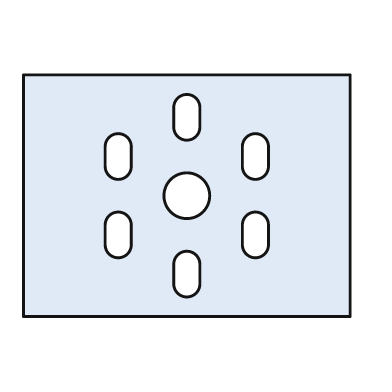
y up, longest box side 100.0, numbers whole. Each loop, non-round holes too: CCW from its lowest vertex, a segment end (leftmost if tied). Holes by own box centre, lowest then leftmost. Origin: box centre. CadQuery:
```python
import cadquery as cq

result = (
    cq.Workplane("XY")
    .moveTo(-50.0, -37.0)
    .lineTo(50.0, -37.0)
    .lineTo(50.0, 37.0)
    .lineTo(-50.0, 37.0)
    .close()
    .moveTo(-4.0, -27.0)
    .threePointArc((0.0, -31.0), (4.0, -27.0))
    .lineTo(4.0, -21.0)
    .threePointArc((0.0, -17.0), (-4.0, -21.0))
    .close()
    .moveTo(-25.0, -15.0)
    .threePointArc((-21.0, -19.0), (-17.0, -15.0))
    .lineTo(-17.0, -9.0)
    .threePointArc((-21.0, -5.0), (-25.0, -9.0))
    .close()
    .moveTo(17.0, -15.0)
    .threePointArc((21.0, -19.0), (25.0, -15.0))
    .lineTo(25.0, -9.0)
    .threePointArc((21.0, -5.0), (17.0, -9.0))
    .close()
    .moveTo(0.0, 0.0)
    .circle(7.0)
    .moveTo(-25.0, 9.0)
    .threePointArc((-21.0, 5.0), (-17.0, 9.0))
    .lineTo(-17.0, 15.0)
    .threePointArc((-21.0, 19.0), (-25.0, 15.0))
    .close()
    .moveTo(17.0, 9.0)
    .threePointArc((21.0, 5.0), (25.0, 9.0))
    .lineTo(25.0, 15.0)
    .threePointArc((21.0, 19.0), (17.0, 15.0))
    .close()
    .moveTo(-4.0, 21.0)
    .threePointArc((0.0, 17.0), (4.0, 21.0))
    .lineTo(4.0, 27.0)
    .threePointArc((0.0, 31.0), (-4.0, 27.0))
    .close()
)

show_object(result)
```